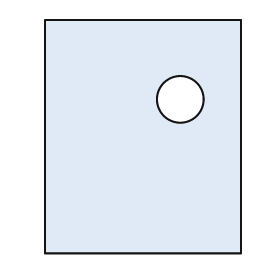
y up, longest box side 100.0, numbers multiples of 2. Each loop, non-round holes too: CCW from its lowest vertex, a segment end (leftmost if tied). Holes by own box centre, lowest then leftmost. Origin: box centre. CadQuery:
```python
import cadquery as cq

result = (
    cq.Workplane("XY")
    .moveTo(-42.0, -50.0)
    .lineTo(42.0, -50.0)
    .lineTo(42.0, 50.0)
    .lineTo(-42.0, 50.0)
    .close()
    .moveTo(16.0, 16.0)
    .circle(10.0)
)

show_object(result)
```